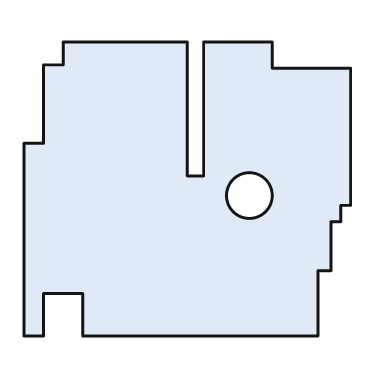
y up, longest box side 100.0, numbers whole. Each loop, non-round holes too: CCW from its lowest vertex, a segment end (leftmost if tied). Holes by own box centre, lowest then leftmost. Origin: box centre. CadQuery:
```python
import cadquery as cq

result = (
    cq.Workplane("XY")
    .moveTo(-50.0, -45.0)
    .lineTo(-44.0, -45.0)
    .lineTo(-44.0, -32.0)
    .lineTo(-32.0, -32.0)
    .lineTo(-32.0, -45.0)
    .lineTo(40.0, -45.0)
    .lineTo(40.0, -25.0)
    .lineTo(44.0, -25.0)
    .lineTo(44.0, -10.0)
    .lineTo(47.0, -10.0)
    .lineTo(47.0, -5.0)
    .lineTo(50.0, -5.0)
    .lineTo(50.0, 37.0)
    .lineTo(26.0, 37.0)
    .lineTo(26.0, 45.0)
    .lineTo(5.0, 45.0)
    .lineTo(5.0, 4.0)
    .lineTo(0.0, 4.0)
    .lineTo(0.0, 45.0)
    .lineTo(-38.0, 45.0)
    .lineTo(-38.0, 38.0)
    .lineTo(-44.0, 38.0)
    .lineTo(-44.0, 14.0)
    .lineTo(-50.0, 14.0)
    .close()
    .moveTo(19.0, -2.0)
    .circle(7.0)
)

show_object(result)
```